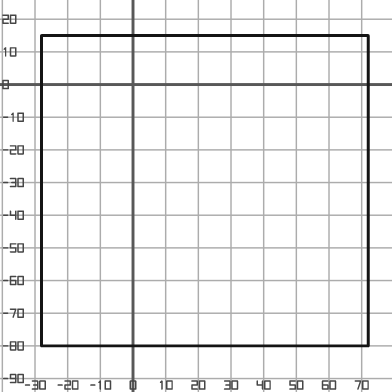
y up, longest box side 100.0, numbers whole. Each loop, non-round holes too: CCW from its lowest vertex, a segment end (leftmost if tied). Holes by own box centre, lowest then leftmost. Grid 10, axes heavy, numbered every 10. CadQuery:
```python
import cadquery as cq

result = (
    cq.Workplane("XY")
    .moveTo(-28.0, -80.0)
    .lineTo(72.0, -80.0)
    .lineTo(72.0, 15.0)
    .lineTo(-28.0, 15.0)
    .close()
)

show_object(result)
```